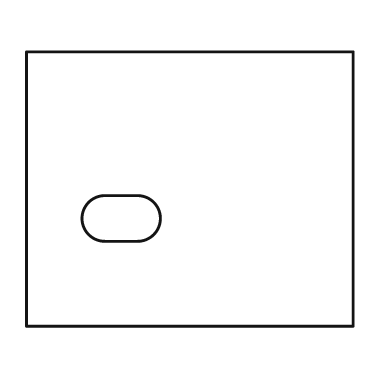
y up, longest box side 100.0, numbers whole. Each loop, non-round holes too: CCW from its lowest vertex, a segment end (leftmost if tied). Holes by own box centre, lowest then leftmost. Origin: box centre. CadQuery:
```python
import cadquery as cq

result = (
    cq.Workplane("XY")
    .moveTo(-50.0, -42.0)
    .lineTo(50.0, -42.0)
    .lineTo(50.0, 42.0)
    .lineTo(-50.0, 42.0)
    .close()
    .moveTo(-26.0, -16.0)
    .lineTo(-16.0, -16.0)
    .threePointArc((-9.0, -9.0), (-16.0, -2.0))
    .lineTo(-26.0, -2.0)
    .threePointArc((-33.0, -9.0), (-26.0, -16.0))
    .close()
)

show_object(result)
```